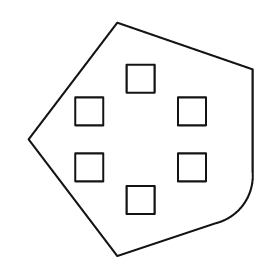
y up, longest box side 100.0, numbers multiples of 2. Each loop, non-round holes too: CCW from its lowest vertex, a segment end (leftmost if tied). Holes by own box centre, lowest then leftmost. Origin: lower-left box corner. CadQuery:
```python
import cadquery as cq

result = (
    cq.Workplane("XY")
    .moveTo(38.0, 0.0)
    .lineTo(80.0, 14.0)
    .threePointArc((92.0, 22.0), (96.0, 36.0))
    .lineTo(96.0, 80.0)
    .lineTo(38.0, 100.0)
    .lineTo(0.0, 50.0)
    .close()
    .moveTo(42.0, 18.0)
    .lineTo(54.0, 18.0)
    .lineTo(54.0, 30.0)
    .lineTo(42.0, 30.0)
    .close()
    .moveTo(20.0, 32.0)
    .lineTo(32.0, 32.0)
    .lineTo(32.0, 44.0)
    .lineTo(20.0, 44.0)
    .close()
    .moveTo(64.0, 32.0)
    .lineTo(76.0, 32.0)
    .lineTo(76.0, 44.0)
    .lineTo(64.0, 44.0)
    .close()
    .moveTo(20.0, 56.0)
    .lineTo(32.0, 56.0)
    .lineTo(32.0, 68.0)
    .lineTo(20.0, 68.0)
    .close()
    .moveTo(64.0, 56.0)
    .lineTo(76.0, 56.0)
    .lineTo(76.0, 68.0)
    .lineTo(64.0, 68.0)
    .close()
    .moveTo(42.0, 70.0)
    .lineTo(54.0, 70.0)
    .lineTo(54.0, 82.0)
    .lineTo(42.0, 82.0)
    .close()
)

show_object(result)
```